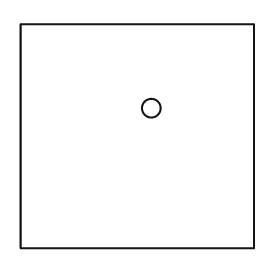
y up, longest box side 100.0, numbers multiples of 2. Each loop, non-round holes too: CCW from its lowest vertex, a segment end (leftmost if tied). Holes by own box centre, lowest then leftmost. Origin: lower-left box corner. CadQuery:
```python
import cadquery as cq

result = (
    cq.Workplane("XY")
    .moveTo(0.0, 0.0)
    .lineTo(100.0, 0.0)
    .lineTo(100.0, 96.0)
    .lineTo(0.0, 96.0)
    .close()
    .moveTo(56.0, 60.0)
    .circle(4.0)
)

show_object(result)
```